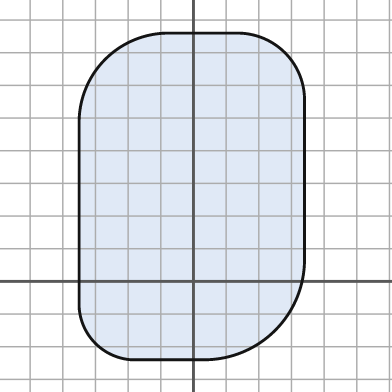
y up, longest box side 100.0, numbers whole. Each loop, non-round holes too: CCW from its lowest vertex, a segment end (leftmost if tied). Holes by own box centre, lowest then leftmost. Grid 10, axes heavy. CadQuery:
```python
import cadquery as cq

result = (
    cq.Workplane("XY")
    .moveTo(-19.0, -24.0)
    .lineTo(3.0, -24.0)
    .threePointArc((25.0, -15.0), (34.0, 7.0))
    .lineTo(34.0, 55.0)
    .threePointArc((28.0, 70.0), (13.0, 76.0))
    .lineTo(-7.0, 76.0)
    .threePointArc((-27.0, 68.0), (-35.0, 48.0))
    .lineTo(-35.0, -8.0)
    .threePointArc((-30.0, -19.0), (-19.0, -24.0))
    .close()
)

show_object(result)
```